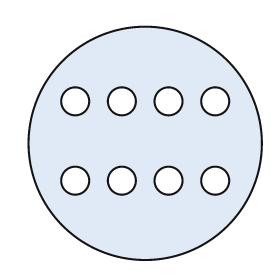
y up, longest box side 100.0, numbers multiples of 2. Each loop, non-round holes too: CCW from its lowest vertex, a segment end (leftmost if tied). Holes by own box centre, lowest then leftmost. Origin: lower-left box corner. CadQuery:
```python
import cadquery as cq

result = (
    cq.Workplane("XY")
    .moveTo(50.0, 50.0)
    .circle(50.0)
    .moveTo(20.0, 34.0)
    .circle(6.0)
    .moveTo(40.0, 34.0)
    .circle(6.0)
    .moveTo(60.0, 34.0)
    .circle(6.0)
    .moveTo(80.0, 34.0)
    .circle(6.0)
    .moveTo(20.0, 68.0)
    .circle(6.0)
    .moveTo(40.0, 68.0)
    .circle(6.0)
    .moveTo(60.0, 68.0)
    .circle(6.0)
    .moveTo(80.0, 68.0)
    .circle(6.0)
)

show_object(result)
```